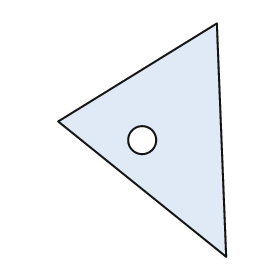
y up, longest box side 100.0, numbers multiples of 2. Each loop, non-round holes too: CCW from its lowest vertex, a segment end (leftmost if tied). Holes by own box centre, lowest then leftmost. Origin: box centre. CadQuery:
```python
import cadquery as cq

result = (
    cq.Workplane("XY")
    .moveTo(36.0, -50.0)
    .lineTo(32.0, 50.0)
    .lineTo(-36.0, 8.0)
    .close()
    .moveTo(0.0, 0.0)
    .circle(6.0)
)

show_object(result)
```